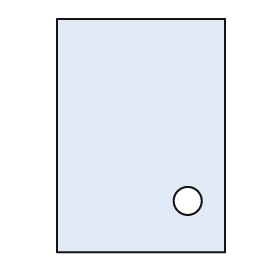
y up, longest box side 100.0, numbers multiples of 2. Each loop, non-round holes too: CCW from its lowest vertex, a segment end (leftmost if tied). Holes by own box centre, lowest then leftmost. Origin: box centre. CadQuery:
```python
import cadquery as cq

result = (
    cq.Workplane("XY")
    .moveTo(-36.0, -50.0)
    .lineTo(36.0, -50.0)
    .lineTo(36.0, 50.0)
    .lineTo(-36.0, 50.0)
    .close()
    .moveTo(20.0, -28.0)
    .circle(6.0)
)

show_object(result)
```